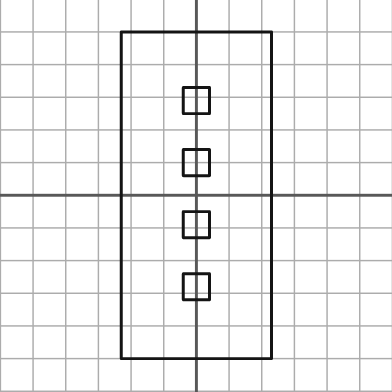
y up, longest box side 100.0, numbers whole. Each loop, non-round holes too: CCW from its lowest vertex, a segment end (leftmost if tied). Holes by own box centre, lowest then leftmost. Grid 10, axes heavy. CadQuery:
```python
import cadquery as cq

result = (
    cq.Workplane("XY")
    .moveTo(-23.0, -50.0)
    .lineTo(23.0, -50.0)
    .lineTo(23.0, 50.0)
    .lineTo(-23.0, 50.0)
    .close()
    .moveTo(-4.0, -32.0)
    .lineTo(4.0, -32.0)
    .lineTo(4.0, -24.0)
    .lineTo(-4.0, -24.0)
    .close()
    .moveTo(-4.0, -13.0)
    .lineTo(4.0, -13.0)
    .lineTo(4.0, -5.0)
    .lineTo(-4.0, -5.0)
    .close()
    .moveTo(-4.0, 6.0)
    .lineTo(4.0, 6.0)
    .lineTo(4.0, 14.0)
    .lineTo(-4.0, 14.0)
    .close()
    .moveTo(-4.0, 25.0)
    .lineTo(4.0, 25.0)
    .lineTo(4.0, 33.0)
    .lineTo(-4.0, 33.0)
    .close()
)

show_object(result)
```